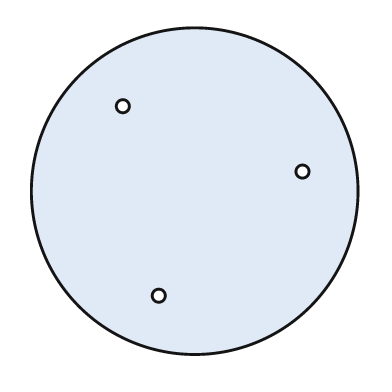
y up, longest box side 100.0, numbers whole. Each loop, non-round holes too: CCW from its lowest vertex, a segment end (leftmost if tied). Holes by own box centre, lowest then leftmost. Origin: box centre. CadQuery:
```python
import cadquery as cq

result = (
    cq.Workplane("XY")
    .moveTo(0.0, 0.0)
    .circle(50.0)
    .moveTo(-11.0, -32.0)
    .circle(2.0)
    .moveTo(33.0, 6.0)
    .circle(2.0)
    .moveTo(-22.0, 26.0)
    .circle(2.0)
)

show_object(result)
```